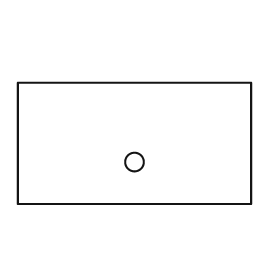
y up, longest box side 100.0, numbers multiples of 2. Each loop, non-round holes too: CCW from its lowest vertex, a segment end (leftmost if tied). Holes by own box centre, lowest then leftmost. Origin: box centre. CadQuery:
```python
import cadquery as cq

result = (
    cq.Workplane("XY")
    .moveTo(-50.0, -26.0)
    .lineTo(50.0, -26.0)
    .lineTo(50.0, 26.0)
    .lineTo(-50.0, 26.0)
    .close()
    .moveTo(0.0, -8.0)
    .circle(4.0)
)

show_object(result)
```